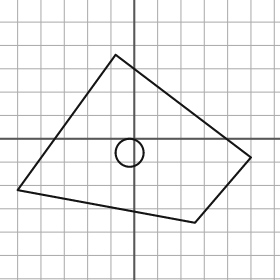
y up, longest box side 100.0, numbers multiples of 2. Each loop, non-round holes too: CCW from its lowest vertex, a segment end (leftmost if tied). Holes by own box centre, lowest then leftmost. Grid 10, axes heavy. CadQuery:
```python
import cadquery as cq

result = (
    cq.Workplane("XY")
    .moveTo(26.0, -36.0)
    .lineTo(50.0, -8.0)
    .lineTo(-8.0, 36.0)
    .lineTo(-50.0, -22.0)
    .close()
    .moveTo(-2.0, -6.0)
    .circle(6.0)
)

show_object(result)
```